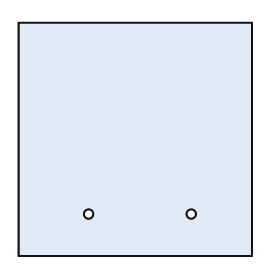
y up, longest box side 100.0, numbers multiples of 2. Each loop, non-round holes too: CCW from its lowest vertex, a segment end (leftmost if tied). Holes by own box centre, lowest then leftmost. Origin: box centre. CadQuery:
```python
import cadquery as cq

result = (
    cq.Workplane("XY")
    .moveTo(-50.0, -50.0)
    .lineTo(50.0, -50.0)
    .lineTo(50.0, 50.0)
    .lineTo(-50.0, 50.0)
    .close()
    .moveTo(-20.0, -32.0)
    .circle(2.0)
    .moveTo(24.0, -32.0)
    .circle(2.0)
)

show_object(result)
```